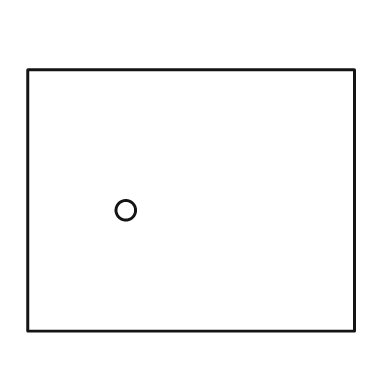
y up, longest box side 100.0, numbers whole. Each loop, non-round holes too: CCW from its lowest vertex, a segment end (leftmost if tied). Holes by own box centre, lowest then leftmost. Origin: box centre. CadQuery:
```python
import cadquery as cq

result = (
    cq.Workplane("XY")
    .moveTo(-50.0, -40.0)
    .lineTo(50.0, -40.0)
    .lineTo(50.0, 40.0)
    .lineTo(-50.0, 40.0)
    .close()
    .moveTo(-20.0, -3.0)
    .circle(3.0)
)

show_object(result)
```